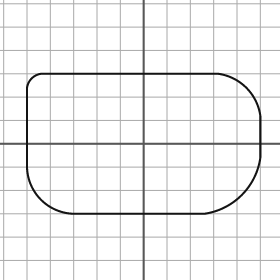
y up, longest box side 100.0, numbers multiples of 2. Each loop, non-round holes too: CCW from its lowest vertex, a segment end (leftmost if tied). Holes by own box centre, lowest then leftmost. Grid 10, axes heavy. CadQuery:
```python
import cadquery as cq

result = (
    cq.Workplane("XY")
    .moveTo(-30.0, -30.0)
    .lineTo(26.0, -30.0)
    .threePointArc((42.0, -22.0), (50.0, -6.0))
    .lineTo(50.0, 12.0)
    .threePointArc((44.0, 24.0), (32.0, 30.0))
    .lineTo(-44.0, 30.0)
    .threePointArc((-48.0, 28.0), (-50.0, 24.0))
    .lineTo(-50.0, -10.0)
    .threePointArc((-44.0, -24.0), (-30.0, -30.0))
    .close()
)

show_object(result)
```